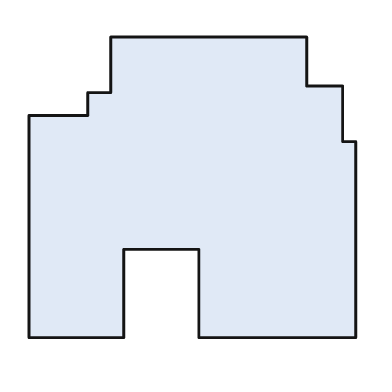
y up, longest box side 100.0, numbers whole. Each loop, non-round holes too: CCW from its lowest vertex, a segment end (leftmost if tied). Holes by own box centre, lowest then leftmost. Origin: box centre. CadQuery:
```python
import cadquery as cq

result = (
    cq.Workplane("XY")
    .moveTo(-50.0, -46.0)
    .lineTo(-21.0, -46.0)
    .lineTo(-21.0, -19.0)
    .lineTo(2.0, -19.0)
    .lineTo(2.0, -46.0)
    .lineTo(50.0, -46.0)
    .lineTo(50.0, 14.0)
    .lineTo(46.0, 14.0)
    .lineTo(46.0, 31.0)
    .lineTo(35.0, 31.0)
    .lineTo(35.0, 46.0)
    .lineTo(-25.0, 46.0)
    .lineTo(-25.0, 29.0)
    .lineTo(-32.0, 29.0)
    .lineTo(-32.0, 22.0)
    .lineTo(-50.0, 22.0)
    .close()
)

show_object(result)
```